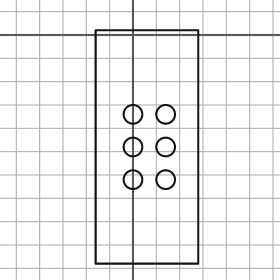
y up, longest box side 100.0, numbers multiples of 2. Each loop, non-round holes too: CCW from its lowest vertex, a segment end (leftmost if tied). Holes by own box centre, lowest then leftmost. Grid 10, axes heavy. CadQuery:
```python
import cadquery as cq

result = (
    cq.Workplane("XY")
    .moveTo(-16.0, -98.0)
    .lineTo(28.0, -98.0)
    .lineTo(28.0, 2.0)
    .lineTo(-16.0, 2.0)
    .close()
    .moveTo(0.0, -62.0)
    .circle(4.0)
    .moveTo(14.0, -62.0)
    .circle(4.0)
    .moveTo(0.0, -48.0)
    .circle(4.0)
    .moveTo(14.0, -48.0)
    .circle(4.0)
    .moveTo(0.0, -34.0)
    .circle(4.0)
    .moveTo(14.0, -34.0)
    .circle(4.0)
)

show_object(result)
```